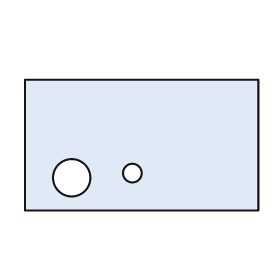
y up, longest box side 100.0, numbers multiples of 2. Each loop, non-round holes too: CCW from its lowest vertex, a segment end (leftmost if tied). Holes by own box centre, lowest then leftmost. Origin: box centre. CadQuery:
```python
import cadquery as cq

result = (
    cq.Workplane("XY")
    .moveTo(-50.0, -28.0)
    .lineTo(50.0, -28.0)
    .lineTo(50.0, 28.0)
    .lineTo(-50.0, 28.0)
    .close()
    .moveTo(-30.0, -14.0)
    .circle(8.0)
    .moveTo(-4.0, -12.0)
    .circle(4.0)
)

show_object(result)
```